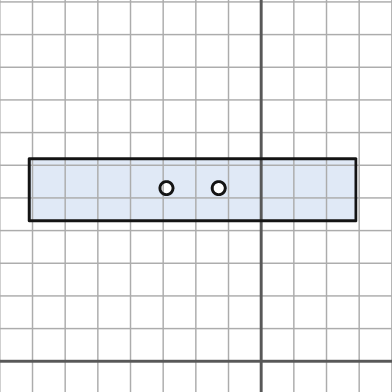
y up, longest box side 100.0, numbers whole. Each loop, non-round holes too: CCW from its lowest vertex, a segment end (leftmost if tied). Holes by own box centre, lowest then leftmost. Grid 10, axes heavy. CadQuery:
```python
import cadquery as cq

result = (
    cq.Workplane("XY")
    .moveTo(-71.0, 43.0)
    .lineTo(29.0, 43.0)
    .lineTo(29.0, 62.0)
    .lineTo(-71.0, 62.0)
    .close()
    .moveTo(-29.0, 53.0)
    .circle(2.0)
    .moveTo(-13.0, 53.0)
    .circle(2.0)
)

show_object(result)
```